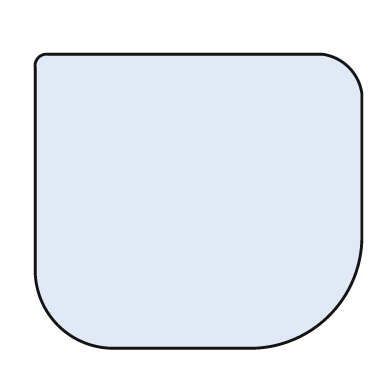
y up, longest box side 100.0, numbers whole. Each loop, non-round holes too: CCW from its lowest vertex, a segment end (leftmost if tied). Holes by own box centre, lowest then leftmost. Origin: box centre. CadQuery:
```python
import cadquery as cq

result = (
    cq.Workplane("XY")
    .moveTo(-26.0, -45.0)
    .lineTo(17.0, -45.0)
    .threePointArc((40.0, -35.0), (50.0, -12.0))
    .lineTo(50.0, 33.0)
    .threePointArc((46.0, 41.0), (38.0, 45.0))
    .lineTo(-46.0, 45.0)
    .threePointArc((-49.0, 44.0), (-50.0, 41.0))
    .lineTo(-50.0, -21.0)
    .threePointArc((-43.0, -38.0), (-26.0, -45.0))
    .close()
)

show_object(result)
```